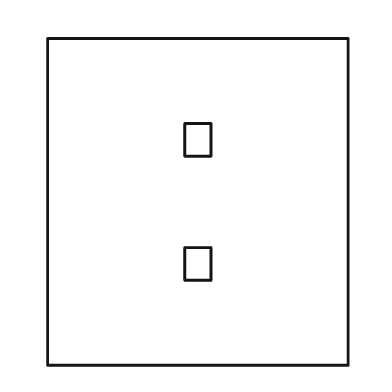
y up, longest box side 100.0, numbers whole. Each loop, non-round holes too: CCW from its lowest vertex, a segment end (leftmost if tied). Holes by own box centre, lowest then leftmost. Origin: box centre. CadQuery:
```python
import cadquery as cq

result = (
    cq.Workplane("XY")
    .moveTo(-46.0, -50.0)
    .lineTo(46.0, -50.0)
    .lineTo(46.0, 50.0)
    .lineTo(-46.0, 50.0)
    .close()
    .moveTo(-4.0, -24.0)
    .lineTo(4.0, -24.0)
    .lineTo(4.0, -14.0)
    .lineTo(-4.0, -14.0)
    .close()
    .moveTo(-4.0, 14.0)
    .lineTo(4.0, 14.0)
    .lineTo(4.0, 24.0)
    .lineTo(-4.0, 24.0)
    .close()
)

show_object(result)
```